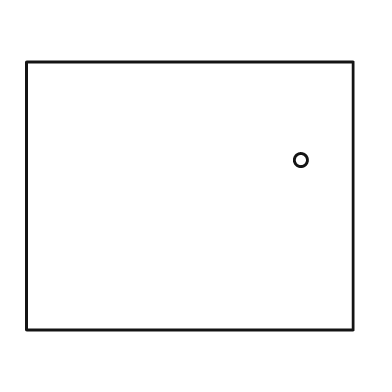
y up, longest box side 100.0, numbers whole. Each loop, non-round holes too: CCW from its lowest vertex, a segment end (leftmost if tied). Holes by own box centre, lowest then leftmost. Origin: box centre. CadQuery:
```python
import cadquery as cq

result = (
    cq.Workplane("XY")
    .moveTo(-50.0, -41.0)
    .lineTo(50.0, -41.0)
    .lineTo(50.0, 41.0)
    .lineTo(-50.0, 41.0)
    .close()
    .moveTo(34.0, 11.0)
    .circle(2.0)
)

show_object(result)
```